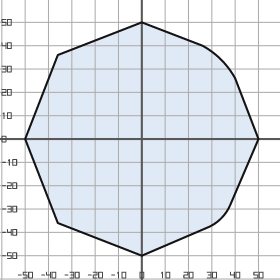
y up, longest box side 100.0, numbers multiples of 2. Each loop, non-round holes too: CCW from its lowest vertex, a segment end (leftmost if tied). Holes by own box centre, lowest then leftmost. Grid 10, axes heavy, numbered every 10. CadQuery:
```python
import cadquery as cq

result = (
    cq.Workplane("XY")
    .moveTo(0.0, -50.0)
    .lineTo(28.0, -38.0)
    .threePointArc((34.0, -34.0), (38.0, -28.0))
    .lineTo(50.0, 0.0)
    .lineTo(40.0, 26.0)
    .threePointArc((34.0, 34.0), (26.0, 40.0))
    .lineTo(0.0, 50.0)
    .lineTo(-36.0, 36.0)
    .lineTo(-50.0, 0.0)
    .lineTo(-36.0, -36.0)
    .close()
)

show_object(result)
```